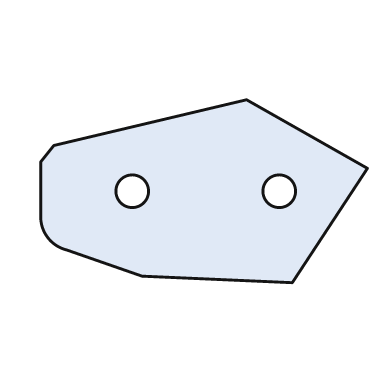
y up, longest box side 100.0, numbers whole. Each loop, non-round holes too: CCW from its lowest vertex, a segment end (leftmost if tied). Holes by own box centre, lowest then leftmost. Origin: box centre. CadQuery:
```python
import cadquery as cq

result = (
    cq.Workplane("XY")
    .moveTo(27.0, -28.0)
    .lineTo(50.0, 7.0)
    .lineTo(13.0, 28.0)
    .lineTo(-46.0, 14.0)
    .lineTo(-50.0, 9.0)
    .lineTo(-50.0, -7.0)
    .threePointArc((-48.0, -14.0), (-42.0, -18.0))
    .lineTo(-19.0, -26.0)
    .close()
    .moveTo(-22.0, 0.0)
    .circle(5.0)
    .moveTo(23.0, 0.0)
    .circle(5.0)
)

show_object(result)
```